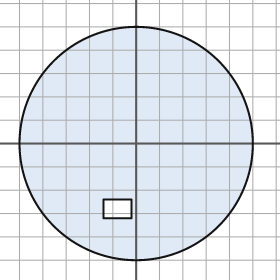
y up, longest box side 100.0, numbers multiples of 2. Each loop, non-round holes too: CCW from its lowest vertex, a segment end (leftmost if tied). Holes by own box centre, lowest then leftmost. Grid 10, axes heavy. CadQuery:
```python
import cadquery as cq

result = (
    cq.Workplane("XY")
    .moveTo(0.0, 0.0)
    .circle(50.0)
    .moveTo(-14.0, -32.0)
    .lineTo(-2.0, -32.0)
    .lineTo(-2.0, -24.0)
    .lineTo(-14.0, -24.0)
    .close()
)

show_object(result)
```